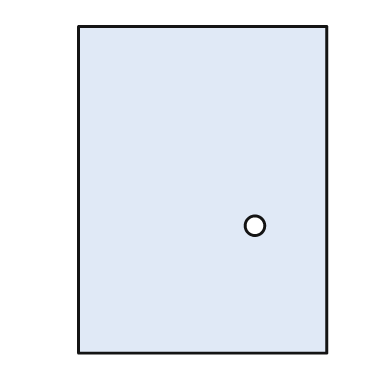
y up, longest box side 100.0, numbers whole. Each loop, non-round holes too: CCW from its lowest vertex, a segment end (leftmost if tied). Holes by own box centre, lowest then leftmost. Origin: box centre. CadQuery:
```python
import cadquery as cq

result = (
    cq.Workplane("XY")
    .moveTo(-38.0, -50.0)
    .lineTo(38.0, -50.0)
    .lineTo(38.0, 50.0)
    .lineTo(-38.0, 50.0)
    .close()
    .moveTo(16.0, -11.0)
    .circle(3.0)
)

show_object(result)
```